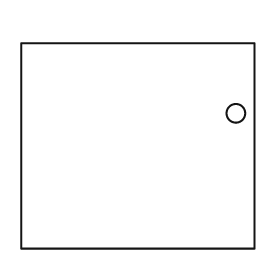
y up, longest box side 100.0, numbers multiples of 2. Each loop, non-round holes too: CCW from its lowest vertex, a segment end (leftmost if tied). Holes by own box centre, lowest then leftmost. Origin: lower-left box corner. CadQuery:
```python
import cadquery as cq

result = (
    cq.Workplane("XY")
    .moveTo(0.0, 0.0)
    .lineTo(100.0, 0.0)
    .lineTo(100.0, 88.0)
    .lineTo(0.0, 88.0)
    .close()
    .moveTo(92.0, 58.0)
    .circle(4.0)
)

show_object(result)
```